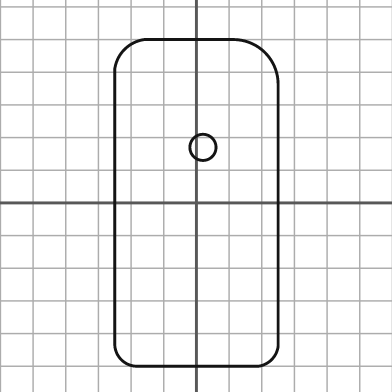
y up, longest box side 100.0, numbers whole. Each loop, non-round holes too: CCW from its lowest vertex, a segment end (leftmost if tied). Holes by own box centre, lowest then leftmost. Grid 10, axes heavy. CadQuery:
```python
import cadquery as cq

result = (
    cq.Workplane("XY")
    .moveTo(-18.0, -50.0)
    .lineTo(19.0, -50.0)
    .threePointArc((23.0, -48.0), (25.0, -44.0))
    .lineTo(25.0, 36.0)
    .threePointArc((21.0, 46.0), (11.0, 50.0))
    .lineTo(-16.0, 50.0)
    .threePointArc((-22.0, 47.0), (-25.0, 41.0))
    .lineTo(-25.0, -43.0)
    .threePointArc((-23.0, -48.0), (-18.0, -50.0))
    .close()
    .moveTo(2.0, 17.0)
    .circle(4.0)
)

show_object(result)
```